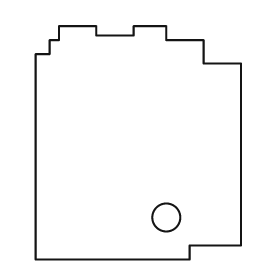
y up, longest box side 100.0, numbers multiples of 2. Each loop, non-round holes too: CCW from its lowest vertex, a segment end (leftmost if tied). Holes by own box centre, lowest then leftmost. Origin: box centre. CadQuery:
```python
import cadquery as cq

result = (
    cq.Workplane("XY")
    .moveTo(-44.0, -50.0)
    .lineTo(22.0, -50.0)
    .lineTo(22.0, -44.0)
    .lineTo(44.0, -44.0)
    .lineTo(44.0, 34.0)
    .lineTo(28.0, 34.0)
    .lineTo(28.0, 44.0)
    .lineTo(12.0, 44.0)
    .lineTo(12.0, 50.0)
    .lineTo(-2.0, 50.0)
    .lineTo(-2.0, 46.0)
    .lineTo(-18.0, 46.0)
    .lineTo(-18.0, 50.0)
    .lineTo(-34.0, 50.0)
    .lineTo(-34.0, 44.0)
    .lineTo(-38.0, 44.0)
    .lineTo(-38.0, 38.0)
    .lineTo(-44.0, 38.0)
    .close()
    .moveTo(12.0, -32.0)
    .circle(6.0)
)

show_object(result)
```